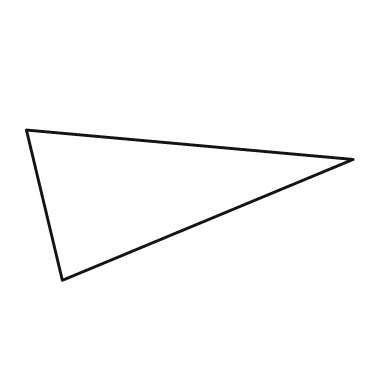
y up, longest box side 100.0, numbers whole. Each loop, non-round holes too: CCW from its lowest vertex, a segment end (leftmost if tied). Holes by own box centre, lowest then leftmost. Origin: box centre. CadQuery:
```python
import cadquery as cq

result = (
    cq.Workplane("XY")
    .moveTo(-39.0, -23.0)
    .lineTo(50.0, 14.0)
    .lineTo(-50.0, 23.0)
    .close()
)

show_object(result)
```